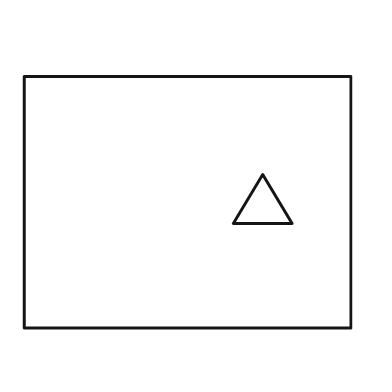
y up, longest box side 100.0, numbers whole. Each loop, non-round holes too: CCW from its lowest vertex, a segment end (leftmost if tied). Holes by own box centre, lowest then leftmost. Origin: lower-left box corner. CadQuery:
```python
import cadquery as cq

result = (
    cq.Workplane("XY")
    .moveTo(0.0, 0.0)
    .lineTo(100.0, 0.0)
    .lineTo(100.0, 77.0)
    .lineTo(0.0, 77.0)
    .close()
    .moveTo(64.0, 32.0)
    .lineTo(82.0, 32.0)
    .lineTo(73.0, 47.0)
    .close()
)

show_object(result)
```